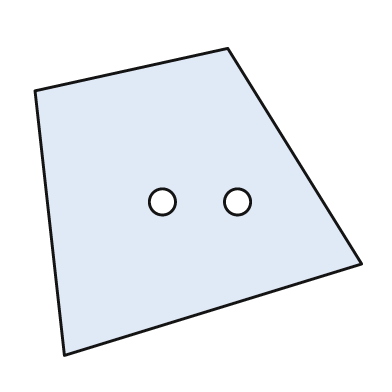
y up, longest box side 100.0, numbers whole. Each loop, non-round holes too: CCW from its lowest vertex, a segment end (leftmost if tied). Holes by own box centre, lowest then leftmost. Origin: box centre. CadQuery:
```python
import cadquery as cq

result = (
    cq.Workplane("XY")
    .moveTo(-41.0, -47.0)
    .lineTo(50.0, -19.0)
    .lineTo(9.0, 47.0)
    .lineTo(-50.0, 34.0)
    .close()
    .moveTo(-11.0, 0.0)
    .circle(4.0)
    .moveTo(12.0, 0.0)
    .circle(4.0)
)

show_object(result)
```